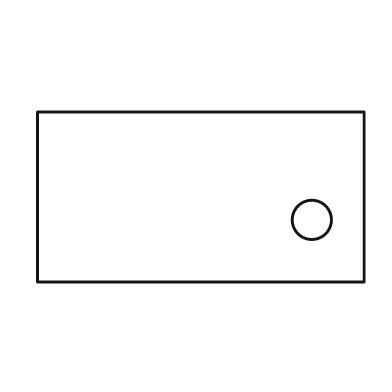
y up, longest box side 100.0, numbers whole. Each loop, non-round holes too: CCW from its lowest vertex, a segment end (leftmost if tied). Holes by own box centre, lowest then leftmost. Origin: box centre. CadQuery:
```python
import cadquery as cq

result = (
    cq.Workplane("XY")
    .moveTo(-50.0, -26.0)
    .lineTo(50.0, -26.0)
    .lineTo(50.0, 26.0)
    .lineTo(-50.0, 26.0)
    .close()
    .moveTo(34.0, -7.0)
    .circle(6.0)
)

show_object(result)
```